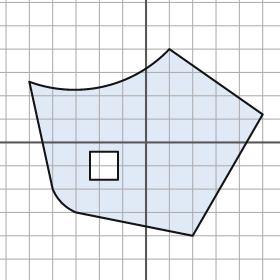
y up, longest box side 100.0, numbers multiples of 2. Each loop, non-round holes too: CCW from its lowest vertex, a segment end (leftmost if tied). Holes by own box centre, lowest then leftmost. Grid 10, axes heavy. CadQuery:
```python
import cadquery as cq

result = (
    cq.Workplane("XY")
    .moveTo(20.0, -40.0)
    .lineTo(50.0, 12.0)
    .lineTo(10.0, 40.0)
    .threePointArc((-18.0, 24.0), (-50.0, 26.0))
    .lineTo(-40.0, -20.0)
    .threePointArc((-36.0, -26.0), (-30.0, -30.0))
    .close()
    .moveTo(-24.0, -16.0)
    .lineTo(-12.0, -16.0)
    .lineTo(-12.0, -4.0)
    .lineTo(-24.0, -4.0)
    .close()
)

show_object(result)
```